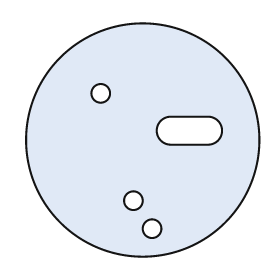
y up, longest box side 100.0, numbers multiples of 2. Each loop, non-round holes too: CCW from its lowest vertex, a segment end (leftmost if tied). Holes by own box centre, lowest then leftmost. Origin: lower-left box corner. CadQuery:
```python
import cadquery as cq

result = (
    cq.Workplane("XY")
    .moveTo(50.0, 50.0)
    .circle(50.0)
    .moveTo(54.0, 12.0)
    .circle(4.0)
    .moveTo(46.0, 24.0)
    .circle(4.0)
    .moveTo(62.0, 48.0)
    .lineTo(78.0, 48.0)
    .threePointArc((84.0, 54.0), (78.0, 60.0))
    .lineTo(62.0, 60.0)
    .threePointArc((56.0, 54.0), (62.0, 48.0))
    .close()
    .moveTo(32.0, 70.0)
    .circle(4.0)
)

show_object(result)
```